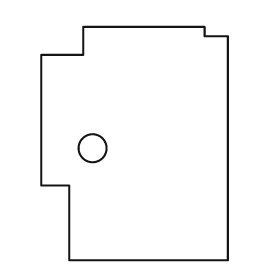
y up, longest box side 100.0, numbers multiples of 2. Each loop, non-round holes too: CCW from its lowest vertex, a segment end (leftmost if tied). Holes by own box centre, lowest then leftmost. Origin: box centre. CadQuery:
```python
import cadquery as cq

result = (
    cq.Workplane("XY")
    .moveTo(-28.0, -50.0)
    .lineTo(40.0, -50.0)
    .lineTo(40.0, 46.0)
    .lineTo(30.0, 46.0)
    .lineTo(30.0, 50.0)
    .lineTo(-22.0, 50.0)
    .lineTo(-22.0, 38.0)
    .lineTo(-40.0, 38.0)
    .lineTo(-40.0, -18.0)
    .lineTo(-28.0, -18.0)
    .close()
    .moveTo(-18.0, -2.0)
    .circle(6.0)
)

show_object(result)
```